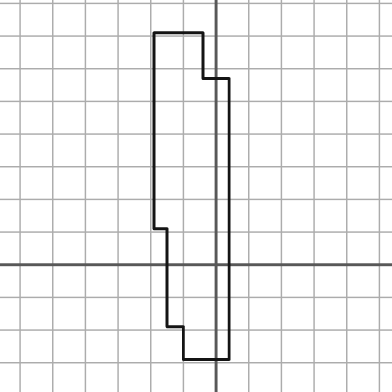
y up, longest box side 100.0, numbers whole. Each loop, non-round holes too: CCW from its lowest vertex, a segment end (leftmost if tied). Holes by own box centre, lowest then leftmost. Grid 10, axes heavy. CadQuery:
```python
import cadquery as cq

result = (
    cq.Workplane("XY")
    .moveTo(-10.0, -29.0)
    .lineTo(4.0, -29.0)
    .lineTo(4.0, 57.0)
    .lineTo(-4.0, 57.0)
    .lineTo(-4.0, 71.0)
    .lineTo(-19.0, 71.0)
    .lineTo(-19.0, 11.0)
    .lineTo(-15.0, 11.0)
    .lineTo(-15.0, -19.0)
    .lineTo(-10.0, -19.0)
    .close()
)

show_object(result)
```